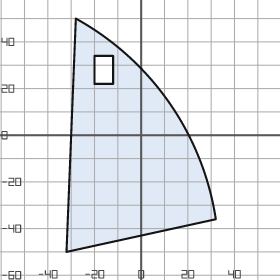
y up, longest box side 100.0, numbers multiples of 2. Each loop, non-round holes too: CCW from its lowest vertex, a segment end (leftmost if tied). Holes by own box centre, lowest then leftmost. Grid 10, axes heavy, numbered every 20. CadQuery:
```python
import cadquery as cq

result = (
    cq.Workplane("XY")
    .moveTo(-32.0, -50.0)
    .lineTo(32.0, -36.0)
    .threePointArc((12.0, 14.0), (-28.0, 50.0))
    .close()
    .moveTo(-20.0, 22.0)
    .lineTo(-12.0, 22.0)
    .lineTo(-12.0, 34.0)
    .lineTo(-20.0, 34.0)
    .close()
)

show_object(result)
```